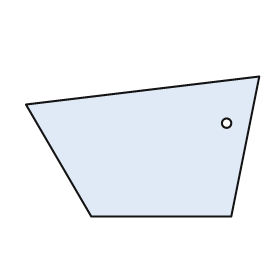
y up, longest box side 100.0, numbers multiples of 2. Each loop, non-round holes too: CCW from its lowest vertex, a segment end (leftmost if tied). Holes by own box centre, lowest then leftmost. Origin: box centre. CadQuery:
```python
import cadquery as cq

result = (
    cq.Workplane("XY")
    .moveTo(-22.0, -30.0)
    .lineTo(38.0, -30.0)
    .lineTo(50.0, 30.0)
    .lineTo(-50.0, 18.0)
    .close()
    .moveTo(36.0, 10.0)
    .circle(2.0)
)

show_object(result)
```